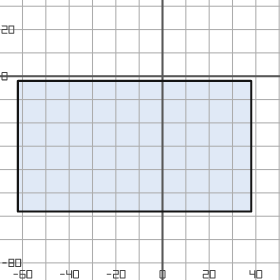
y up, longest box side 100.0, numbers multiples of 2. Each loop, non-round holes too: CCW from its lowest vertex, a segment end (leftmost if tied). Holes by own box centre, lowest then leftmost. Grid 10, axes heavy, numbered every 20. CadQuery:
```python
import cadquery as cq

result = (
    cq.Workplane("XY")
    .moveTo(-62.0, -58.0)
    .lineTo(38.0, -58.0)
    .lineTo(38.0, -2.0)
    .lineTo(-62.0, -2.0)
    .close()
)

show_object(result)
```